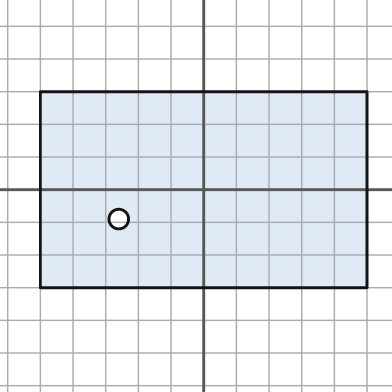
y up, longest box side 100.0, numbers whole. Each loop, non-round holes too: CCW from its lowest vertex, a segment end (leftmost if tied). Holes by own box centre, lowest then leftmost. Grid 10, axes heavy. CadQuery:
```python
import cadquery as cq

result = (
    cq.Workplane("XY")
    .moveTo(-50.0, -30.0)
    .lineTo(50.0, -30.0)
    .lineTo(50.0, 30.0)
    .lineTo(-50.0, 30.0)
    .close()
    .moveTo(-26.0, -9.0)
    .circle(3.0)
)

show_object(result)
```